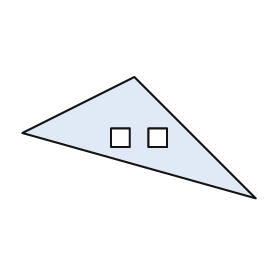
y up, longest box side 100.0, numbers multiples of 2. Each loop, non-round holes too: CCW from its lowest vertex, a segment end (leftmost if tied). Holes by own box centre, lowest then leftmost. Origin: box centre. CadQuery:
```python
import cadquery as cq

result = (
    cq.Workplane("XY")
    .moveTo(50.0, -26.0)
    .lineTo(-2.0, 26.0)
    .lineTo(-50.0, 2.0)
    .close()
    .moveTo(-12.0, -4.0)
    .lineTo(-4.0, -4.0)
    .lineTo(-4.0, 4.0)
    .lineTo(-12.0, 4.0)
    .close()
    .moveTo(4.0, -4.0)
    .lineTo(12.0, -4.0)
    .lineTo(12.0, 4.0)
    .lineTo(4.0, 4.0)
    .close()
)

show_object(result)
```